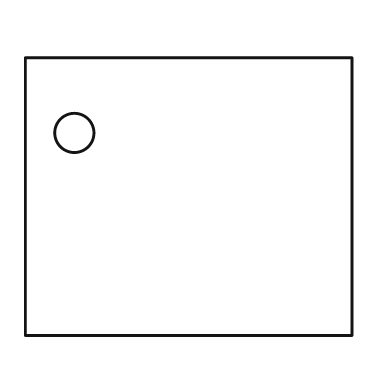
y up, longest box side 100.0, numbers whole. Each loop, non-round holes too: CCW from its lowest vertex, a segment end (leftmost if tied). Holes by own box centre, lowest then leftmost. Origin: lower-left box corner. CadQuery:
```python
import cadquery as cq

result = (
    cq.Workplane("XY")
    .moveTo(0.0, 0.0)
    .lineTo(100.0, 0.0)
    .lineTo(100.0, 85.0)
    .lineTo(0.0, 85.0)
    .close()
    .moveTo(15.0, 62.0)
    .circle(6.0)
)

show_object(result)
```